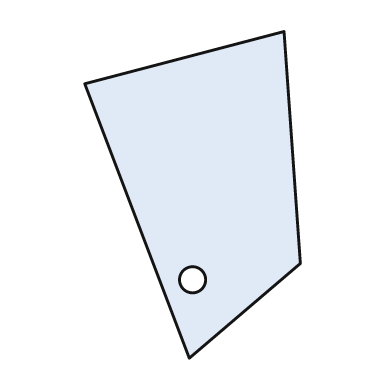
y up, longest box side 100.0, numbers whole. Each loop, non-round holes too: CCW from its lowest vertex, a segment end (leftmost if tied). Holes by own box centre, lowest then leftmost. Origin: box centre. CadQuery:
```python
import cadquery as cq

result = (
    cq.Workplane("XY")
    .moveTo(-1.0, -50.0)
    .lineTo(33.0, -21.0)
    .lineTo(28.0, 50.0)
    .lineTo(-33.0, 34.0)
    .close()
    .moveTo(0.0, -26.0)
    .circle(4.0)
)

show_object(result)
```